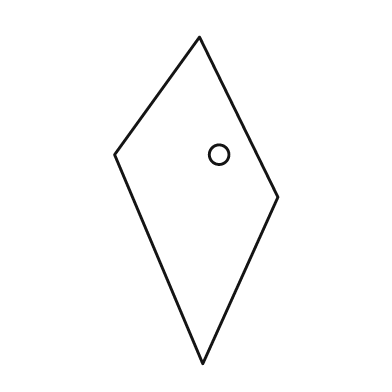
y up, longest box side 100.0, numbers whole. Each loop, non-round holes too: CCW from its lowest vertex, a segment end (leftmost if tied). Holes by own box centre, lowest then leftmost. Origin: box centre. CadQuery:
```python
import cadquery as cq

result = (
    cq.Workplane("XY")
    .moveTo(2.0, -50.0)
    .lineTo(25.0, 1.0)
    .lineTo(1.0, 50.0)
    .lineTo(-25.0, 14.0)
    .close()
    .moveTo(7.0, 14.0)
    .circle(3.0)
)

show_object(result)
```